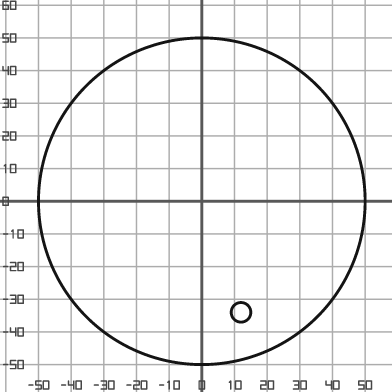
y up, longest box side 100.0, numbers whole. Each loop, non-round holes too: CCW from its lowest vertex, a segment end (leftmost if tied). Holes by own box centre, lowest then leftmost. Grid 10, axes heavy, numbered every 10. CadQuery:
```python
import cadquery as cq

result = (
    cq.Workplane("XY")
    .moveTo(0.0, 0.0)
    .circle(50.0)
    .moveTo(12.0, -34.0)
    .circle(3.0)
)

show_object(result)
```